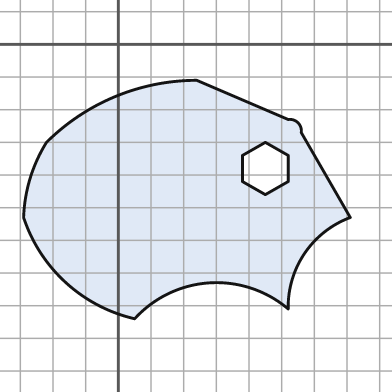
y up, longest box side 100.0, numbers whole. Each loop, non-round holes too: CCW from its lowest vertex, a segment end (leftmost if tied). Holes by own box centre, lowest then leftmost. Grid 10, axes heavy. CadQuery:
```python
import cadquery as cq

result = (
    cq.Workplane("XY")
    .moveTo(5.0, -84.0)
    .threePointArc((28.0, -73.0), (52.0, -81.0))
    .threePointArc((57.0, -64.0), (71.0, -53.0))
    .lineTo(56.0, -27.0)
    .threePointArc((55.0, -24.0), (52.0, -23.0))
    .lineTo(24.0, -11.0)
    .threePointArc((-1.0, -16.0), (-22.0, -30.0))
    .threePointArc((-27.0, -41.0), (-29.0, -53.0))
    .threePointArc((-16.0, -73.0), (5.0, -84.0))
    .close()
    .moveTo(45.0, -46.0)
    .lineTo(52.0, -42.0)
    .lineTo(52.0, -34.0)
    .lineTo(45.0, -30.0)
    .lineTo(38.0, -34.0)
    .lineTo(38.0, -42.0)
    .close()
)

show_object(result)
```